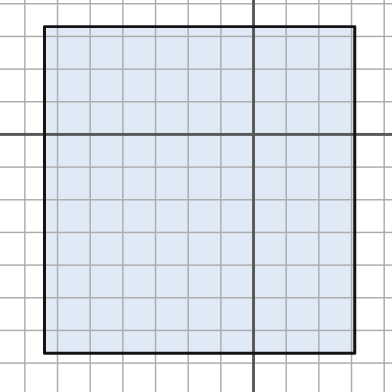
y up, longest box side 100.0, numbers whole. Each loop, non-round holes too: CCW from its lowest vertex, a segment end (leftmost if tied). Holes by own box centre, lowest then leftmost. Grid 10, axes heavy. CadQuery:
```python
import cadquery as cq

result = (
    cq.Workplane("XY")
    .moveTo(-64.0, -67.0)
    .lineTo(31.0, -67.0)
    .lineTo(31.0, 33.0)
    .lineTo(-64.0, 33.0)
    .close()
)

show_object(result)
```